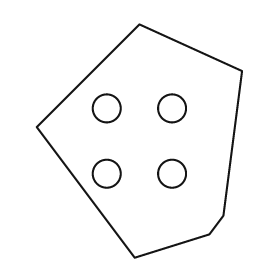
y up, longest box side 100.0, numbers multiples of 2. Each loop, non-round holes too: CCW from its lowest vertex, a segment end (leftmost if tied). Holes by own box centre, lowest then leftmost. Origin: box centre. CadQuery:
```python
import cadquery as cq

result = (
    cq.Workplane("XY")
    .moveTo(-2.0, -50.0)
    .lineTo(30.0, -40.0)
    .lineTo(36.0, -32.0)
    .lineTo(44.0, 30.0)
    .lineTo(0.0, 50.0)
    .lineTo(-44.0, 6.0)
    .close()
    .moveTo(-14.0, -14.0)
    .circle(6.0)
    .moveTo(14.0, -14.0)
    .circle(6.0)
    .moveTo(-14.0, 14.0)
    .circle(6.0)
    .moveTo(14.0, 14.0)
    .circle(6.0)
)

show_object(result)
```